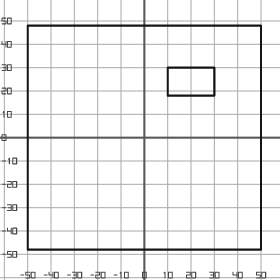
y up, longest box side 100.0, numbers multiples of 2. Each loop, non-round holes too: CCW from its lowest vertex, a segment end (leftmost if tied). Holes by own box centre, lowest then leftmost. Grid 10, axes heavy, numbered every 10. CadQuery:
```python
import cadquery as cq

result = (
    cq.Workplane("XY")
    .moveTo(-50.0, -48.0)
    .lineTo(50.0, -48.0)
    .lineTo(50.0, 48.0)
    .lineTo(-50.0, 48.0)
    .close()
    .moveTo(10.0, 18.0)
    .lineTo(30.0, 18.0)
    .lineTo(30.0, 30.0)
    .lineTo(10.0, 30.0)
    .close()
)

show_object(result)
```